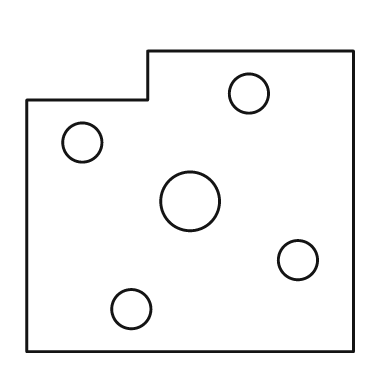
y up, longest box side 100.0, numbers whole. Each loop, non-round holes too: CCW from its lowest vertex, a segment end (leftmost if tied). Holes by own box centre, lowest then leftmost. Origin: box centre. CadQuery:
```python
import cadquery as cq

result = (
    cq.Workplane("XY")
    .moveTo(-50.0, -46.0)
    .lineTo(50.0, -46.0)
    .lineTo(50.0, 46.0)
    .lineTo(-13.0, 46.0)
    .lineTo(-13.0, 31.0)
    .lineTo(-50.0, 31.0)
    .close()
    .moveTo(-18.0, -33.0)
    .circle(6.0)
    .moveTo(33.0, -18.0)
    .circle(6.0)
    .moveTo(0.0, 0.0)
    .circle(9.0)
    .moveTo(-33.0, 18.0)
    .circle(6.0)
    .moveTo(18.0, 33.0)
    .circle(6.0)
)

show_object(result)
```